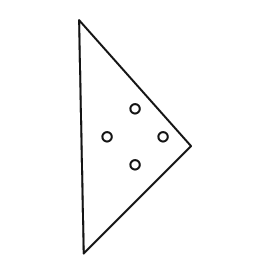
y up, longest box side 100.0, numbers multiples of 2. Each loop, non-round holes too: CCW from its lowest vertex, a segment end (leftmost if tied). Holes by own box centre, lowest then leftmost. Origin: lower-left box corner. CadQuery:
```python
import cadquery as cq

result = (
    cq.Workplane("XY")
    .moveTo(2.0, 0.0)
    .lineTo(48.0, 46.0)
    .lineTo(0.0, 100.0)
    .close()
    .moveTo(24.0, 38.0)
    .circle(2.0)
    .moveTo(12.0, 50.0)
    .circle(2.0)
    .moveTo(36.0, 50.0)
    .circle(2.0)
    .moveTo(24.0, 62.0)
    .circle(2.0)
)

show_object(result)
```